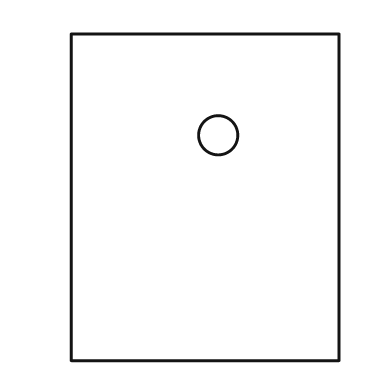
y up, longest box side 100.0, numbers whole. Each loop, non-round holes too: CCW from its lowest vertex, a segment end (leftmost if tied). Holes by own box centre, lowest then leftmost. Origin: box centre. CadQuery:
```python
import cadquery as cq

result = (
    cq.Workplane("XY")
    .moveTo(-41.0, -50.0)
    .lineTo(41.0, -50.0)
    .lineTo(41.0, 50.0)
    .lineTo(-41.0, 50.0)
    .close()
    .moveTo(4.0, 19.0)
    .circle(6.0)
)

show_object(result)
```